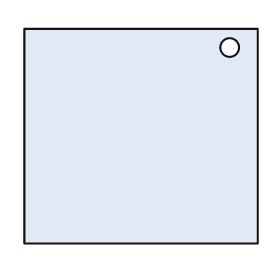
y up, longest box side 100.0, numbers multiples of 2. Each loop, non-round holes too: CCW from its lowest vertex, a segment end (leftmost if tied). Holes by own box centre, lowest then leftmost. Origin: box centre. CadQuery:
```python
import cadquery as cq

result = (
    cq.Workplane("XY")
    .moveTo(-50.0, -46.0)
    .lineTo(50.0, -46.0)
    .lineTo(50.0, 46.0)
    .lineTo(-50.0, 46.0)
    .close()
    .moveTo(38.0, 38.0)
    .circle(4.0)
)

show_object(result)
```